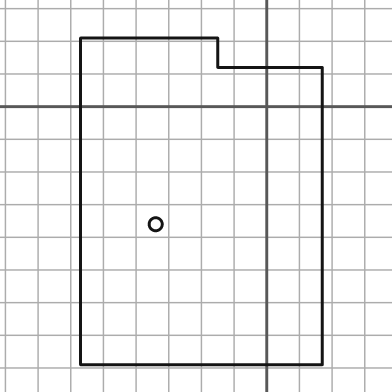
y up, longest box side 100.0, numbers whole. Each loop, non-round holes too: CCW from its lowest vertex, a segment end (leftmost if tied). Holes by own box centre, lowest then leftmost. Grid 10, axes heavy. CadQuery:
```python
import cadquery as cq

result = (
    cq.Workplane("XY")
    .moveTo(-57.0, -79.0)
    .lineTo(17.0, -79.0)
    .lineTo(17.0, 12.0)
    .lineTo(-15.0, 12.0)
    .lineTo(-15.0, 21.0)
    .lineTo(-57.0, 21.0)
    .close()
    .moveTo(-34.0, -36.0)
    .circle(2.0)
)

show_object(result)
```